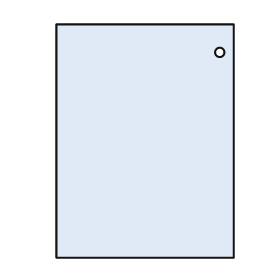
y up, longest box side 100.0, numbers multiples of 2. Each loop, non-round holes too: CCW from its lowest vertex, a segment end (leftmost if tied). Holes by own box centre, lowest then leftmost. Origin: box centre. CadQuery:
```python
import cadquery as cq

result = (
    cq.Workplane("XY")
    .moveTo(-38.0, -50.0)
    .lineTo(38.0, -50.0)
    .lineTo(38.0, 50.0)
    .lineTo(-38.0, 50.0)
    .close()
    .moveTo(32.0, 38.0)
    .circle(2.0)
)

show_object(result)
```